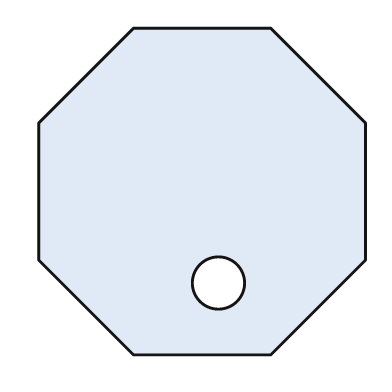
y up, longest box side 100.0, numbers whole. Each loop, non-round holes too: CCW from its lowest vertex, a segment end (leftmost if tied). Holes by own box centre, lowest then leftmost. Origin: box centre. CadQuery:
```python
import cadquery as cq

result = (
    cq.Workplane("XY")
    .moveTo(-21.0, -50.0)
    .lineTo(21.0, -50.0)
    .lineTo(50.0, -21.0)
    .lineTo(50.0, 21.0)
    .lineTo(21.0, 50.0)
    .lineTo(-21.0, 50.0)
    .lineTo(-50.0, 21.0)
    .lineTo(-50.0, -21.0)
    .close()
    .moveTo(5.0, -28.0)
    .circle(8.0)
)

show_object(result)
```